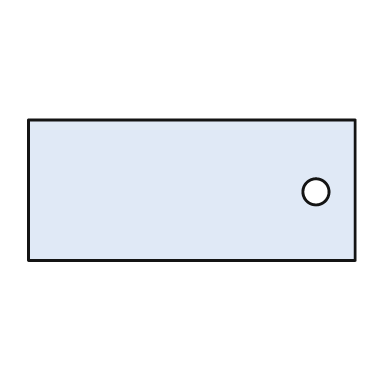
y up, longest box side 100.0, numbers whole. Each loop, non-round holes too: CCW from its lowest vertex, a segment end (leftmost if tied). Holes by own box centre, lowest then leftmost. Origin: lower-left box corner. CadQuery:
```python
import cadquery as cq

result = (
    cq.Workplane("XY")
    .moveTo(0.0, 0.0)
    .lineTo(100.0, 0.0)
    .lineTo(100.0, 43.0)
    .lineTo(0.0, 43.0)
    .close()
    .moveTo(88.0, 21.0)
    .circle(4.0)
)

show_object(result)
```